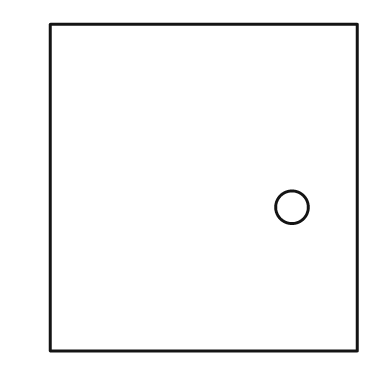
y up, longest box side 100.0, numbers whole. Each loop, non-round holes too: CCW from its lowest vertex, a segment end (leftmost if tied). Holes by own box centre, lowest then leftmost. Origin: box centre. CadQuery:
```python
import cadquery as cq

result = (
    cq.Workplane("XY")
    .moveTo(-47.0, -50.0)
    .lineTo(47.0, -50.0)
    .lineTo(47.0, 50.0)
    .lineTo(-47.0, 50.0)
    .close()
    .moveTo(27.0, -6.0)
    .circle(5.0)
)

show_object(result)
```